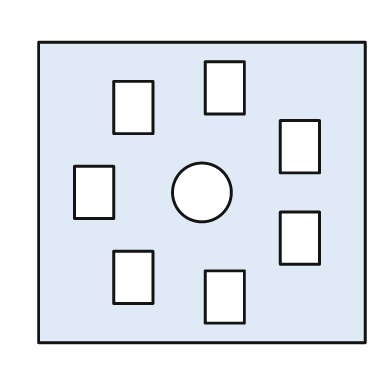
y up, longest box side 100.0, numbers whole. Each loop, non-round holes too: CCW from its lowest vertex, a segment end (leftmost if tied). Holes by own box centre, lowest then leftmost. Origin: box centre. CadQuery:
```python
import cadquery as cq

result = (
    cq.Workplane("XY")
    .moveTo(-50.0, -46.0)
    .lineTo(50.0, -46.0)
    .lineTo(50.0, 46.0)
    .lineTo(-50.0, 46.0)
    .close()
    .moveTo(1.0, -40.0)
    .lineTo(13.0, -40.0)
    .lineTo(13.0, -24.0)
    .lineTo(1.0, -24.0)
    .close()
    .moveTo(-27.0, -34.0)
    .lineTo(-15.0, -34.0)
    .lineTo(-15.0, -18.0)
    .lineTo(-27.0, -18.0)
    .close()
    .moveTo(24.0, -22.0)
    .lineTo(36.0, -22.0)
    .lineTo(36.0, -6.0)
    .lineTo(24.0, -6.0)
    .close()
    .moveTo(-39.0, -8.0)
    .lineTo(-27.0, -8.0)
    .lineTo(-27.0, 8.0)
    .lineTo(-39.0, 8.0)
    .close()
    .moveTo(0.0, 0.0)
    .circle(9.0)
    .moveTo(24.0, 6.0)
    .lineTo(36.0, 6.0)
    .lineTo(36.0, 22.0)
    .lineTo(24.0, 22.0)
    .close()
    .moveTo(-27.0, 18.0)
    .lineTo(-15.0, 18.0)
    .lineTo(-15.0, 34.0)
    .lineTo(-27.0, 34.0)
    .close()
    .moveTo(1.0, 24.0)
    .lineTo(13.0, 24.0)
    .lineTo(13.0, 40.0)
    .lineTo(1.0, 40.0)
    .close()
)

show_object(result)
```